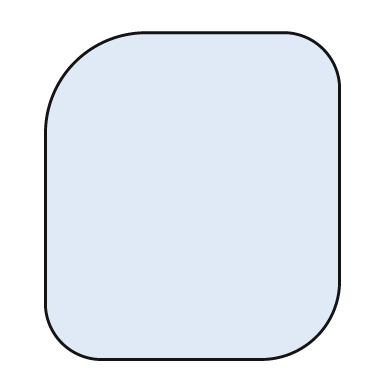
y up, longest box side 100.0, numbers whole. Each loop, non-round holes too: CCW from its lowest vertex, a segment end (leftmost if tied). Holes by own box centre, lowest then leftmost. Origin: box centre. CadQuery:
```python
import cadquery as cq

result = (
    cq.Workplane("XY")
    .moveTo(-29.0, -50.0)
    .lineTo(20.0, -50.0)
    .threePointArc((38.0, -43.0), (45.0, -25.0))
    .lineTo(45.0, 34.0)
    .threePointArc((40.0, 45.0), (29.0, 50.0))
    .lineTo(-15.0, 50.0)
    .threePointArc((-36.0, 41.0), (-45.0, 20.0))
    .lineTo(-45.0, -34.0)
    .threePointArc((-40.0, -45.0), (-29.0, -50.0))
    .close()
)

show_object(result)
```